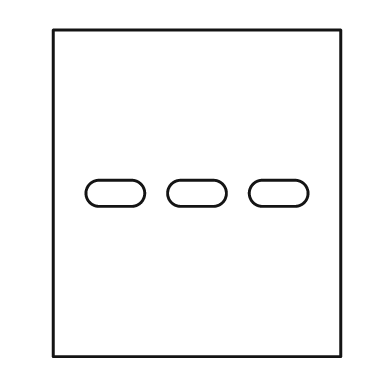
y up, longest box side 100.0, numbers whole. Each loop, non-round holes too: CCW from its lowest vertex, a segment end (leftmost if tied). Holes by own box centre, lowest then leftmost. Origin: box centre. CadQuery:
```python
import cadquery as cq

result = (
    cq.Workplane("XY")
    .moveTo(-44.0, -50.0)
    .lineTo(44.0, -50.0)
    .lineTo(44.0, 50.0)
    .lineTo(-44.0, 50.0)
    .close()
    .moveTo(-30.0, -4.0)
    .lineTo(-20.0, -4.0)
    .threePointArc((-16.0, 0.0), (-20.0, 4.0))
    .lineTo(-30.0, 4.0)
    .threePointArc((-34.0, 0.0), (-30.0, -4.0))
    .close()
    .moveTo(-5.0, -4.0)
    .lineTo(5.0, -4.0)
    .threePointArc((9.0, 0.0), (5.0, 4.0))
    .lineTo(-5.0, 4.0)
    .threePointArc((-9.0, 0.0), (-5.0, -4.0))
    .close()
    .moveTo(20.0, -4.0)
    .lineTo(30.0, -4.0)
    .threePointArc((34.0, 0.0), (30.0, 4.0))
    .lineTo(20.0, 4.0)
    .threePointArc((16.0, 0.0), (20.0, -4.0))
    .close()
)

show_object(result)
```